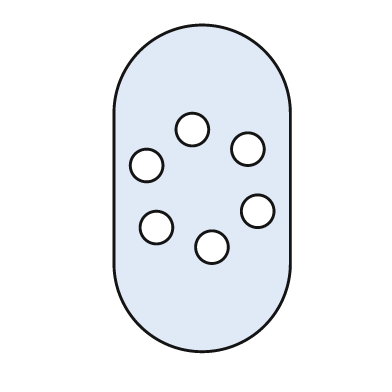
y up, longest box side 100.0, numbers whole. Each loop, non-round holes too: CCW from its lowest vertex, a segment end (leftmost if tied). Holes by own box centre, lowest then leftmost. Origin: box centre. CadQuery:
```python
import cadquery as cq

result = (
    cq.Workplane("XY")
    .moveTo(-27.0, -23.0)
    .threePointArc((0.0, -50.0), (27.0, -23.0))
    .lineTo(27.0, 23.0)
    .threePointArc((0.0, 50.0), (-27.0, 23.0))
    .close()
    .moveTo(3.0, -18.0)
    .circle(5.0)
    .moveTo(-14.0, -12.0)
    .circle(5.0)
    .moveTo(17.0, -7.0)
    .circle(5.0)
    .moveTo(-17.0, 7.0)
    .circle(5.0)
    .moveTo(14.0, 12.0)
    .circle(5.0)
    .moveTo(-3.0, 18.0)
    .circle(5.0)
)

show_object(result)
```